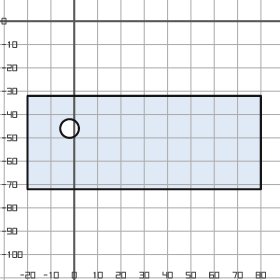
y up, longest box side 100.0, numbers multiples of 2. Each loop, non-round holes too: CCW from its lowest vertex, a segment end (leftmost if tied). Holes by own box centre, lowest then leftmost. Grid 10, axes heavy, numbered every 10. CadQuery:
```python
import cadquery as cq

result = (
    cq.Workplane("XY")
    .moveTo(-20.0, -72.0)
    .lineTo(80.0, -72.0)
    .lineTo(80.0, -32.0)
    .lineTo(-20.0, -32.0)
    .close()
    .moveTo(-2.0, -46.0)
    .circle(4.0)
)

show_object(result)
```